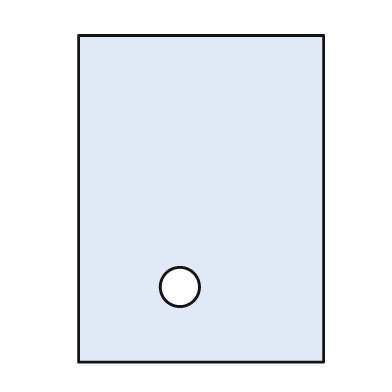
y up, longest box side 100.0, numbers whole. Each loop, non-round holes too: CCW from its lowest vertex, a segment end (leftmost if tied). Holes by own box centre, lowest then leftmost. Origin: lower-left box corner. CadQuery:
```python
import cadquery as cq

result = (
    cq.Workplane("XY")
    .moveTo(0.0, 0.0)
    .lineTo(75.0, 0.0)
    .lineTo(75.0, 100.0)
    .lineTo(0.0, 100.0)
    .close()
    .moveTo(31.0, 23.0)
    .circle(6.0)
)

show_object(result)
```